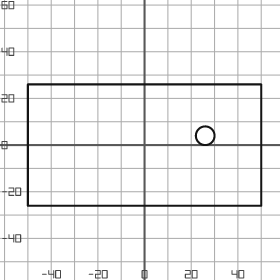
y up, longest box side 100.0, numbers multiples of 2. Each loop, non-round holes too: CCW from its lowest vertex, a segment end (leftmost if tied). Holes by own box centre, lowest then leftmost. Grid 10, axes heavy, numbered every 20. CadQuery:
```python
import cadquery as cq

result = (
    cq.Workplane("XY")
    .moveTo(-50.0, -26.0)
    .lineTo(50.0, -26.0)
    .lineTo(50.0, 26.0)
    .lineTo(-50.0, 26.0)
    .close()
    .moveTo(26.0, 4.0)
    .circle(4.0)
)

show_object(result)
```